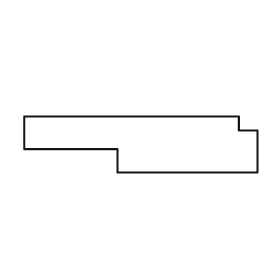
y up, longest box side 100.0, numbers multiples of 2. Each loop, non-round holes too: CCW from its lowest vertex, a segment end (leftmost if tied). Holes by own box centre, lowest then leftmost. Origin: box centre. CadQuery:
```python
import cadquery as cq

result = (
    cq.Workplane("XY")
    .moveTo(-10.0, -12.0)
    .lineTo(50.0, -12.0)
    .lineTo(50.0, 6.0)
    .lineTo(42.0, 6.0)
    .lineTo(42.0, 12.0)
    .lineTo(-50.0, 12.0)
    .lineTo(-50.0, -2.0)
    .lineTo(-10.0, -2.0)
    .close()
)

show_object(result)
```